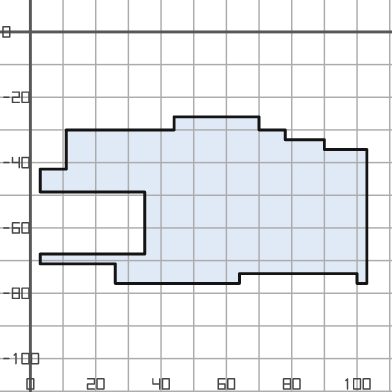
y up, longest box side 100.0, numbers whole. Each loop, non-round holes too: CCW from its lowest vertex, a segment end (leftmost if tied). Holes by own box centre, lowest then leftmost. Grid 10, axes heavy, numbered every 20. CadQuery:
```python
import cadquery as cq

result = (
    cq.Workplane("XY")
    .moveTo(26.0, -77.0)
    .lineTo(64.0, -77.0)
    .lineTo(64.0, -74.0)
    .lineTo(100.0, -74.0)
    .lineTo(100.0, -77.0)
    .lineTo(103.0, -77.0)
    .lineTo(103.0, -36.0)
    .lineTo(90.0, -36.0)
    .lineTo(90.0, -33.0)
    .lineTo(78.0, -33.0)
    .lineTo(78.0, -30.0)
    .lineTo(70.0, -30.0)
    .lineTo(70.0, -26.0)
    .lineTo(44.0, -26.0)
    .lineTo(44.0, -30.0)
    .lineTo(11.0, -30.0)
    .lineTo(11.0, -42.0)
    .lineTo(3.0, -42.0)
    .lineTo(3.0, -49.0)
    .lineTo(35.0, -49.0)
    .lineTo(35.0, -68.0)
    .lineTo(3.0, -68.0)
    .lineTo(3.0, -71.0)
    .lineTo(26.0, -71.0)
    .close()
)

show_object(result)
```